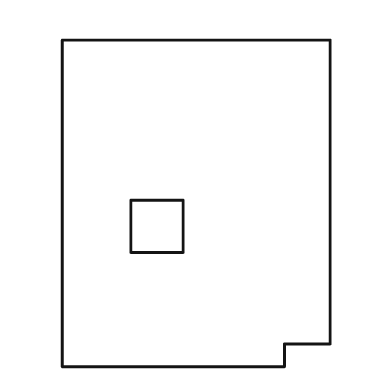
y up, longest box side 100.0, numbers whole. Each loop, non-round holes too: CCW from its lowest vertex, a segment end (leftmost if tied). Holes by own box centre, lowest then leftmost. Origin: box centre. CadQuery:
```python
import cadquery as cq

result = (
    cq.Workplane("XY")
    .moveTo(-41.0, -50.0)
    .lineTo(27.0, -50.0)
    .lineTo(27.0, -43.0)
    .lineTo(41.0, -43.0)
    .lineTo(41.0, 50.0)
    .lineTo(-41.0, 50.0)
    .close()
    .moveTo(-20.0, -15.0)
    .lineTo(-4.0, -15.0)
    .lineTo(-4.0, 1.0)
    .lineTo(-20.0, 1.0)
    .close()
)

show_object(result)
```